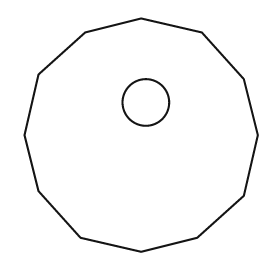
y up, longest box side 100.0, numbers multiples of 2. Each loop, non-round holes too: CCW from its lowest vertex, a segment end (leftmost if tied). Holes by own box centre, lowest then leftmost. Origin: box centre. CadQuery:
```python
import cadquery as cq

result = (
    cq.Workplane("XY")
    .moveTo(0.0, -50.0)
    .lineTo(24.0, -44.0)
    .lineTo(44.0, -26.0)
    .lineTo(50.0, 0.0)
    .lineTo(44.0, 24.0)
    .lineTo(26.0, 44.0)
    .lineTo(0.0, 50.0)
    .lineTo(-24.0, 44.0)
    .lineTo(-44.0, 26.0)
    .lineTo(-50.0, 0.0)
    .lineTo(-44.0, -24.0)
    .lineTo(-26.0, -44.0)
    .close()
    .moveTo(2.0, 14.0)
    .circle(10.0)
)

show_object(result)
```